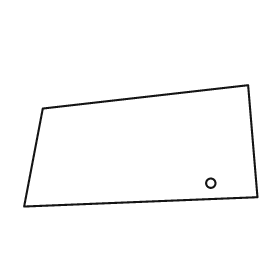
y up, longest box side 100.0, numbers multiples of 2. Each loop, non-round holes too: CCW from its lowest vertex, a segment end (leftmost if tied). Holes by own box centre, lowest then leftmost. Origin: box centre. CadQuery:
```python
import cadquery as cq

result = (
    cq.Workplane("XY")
    .moveTo(-50.0, -26.0)
    .lineTo(50.0, -22.0)
    .lineTo(46.0, 26.0)
    .lineTo(-42.0, 16.0)
    .close()
    .moveTo(30.0, -16.0)
    .circle(2.0)
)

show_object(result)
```